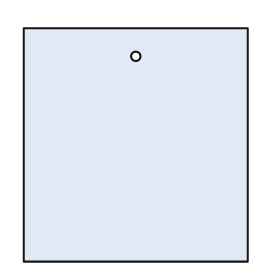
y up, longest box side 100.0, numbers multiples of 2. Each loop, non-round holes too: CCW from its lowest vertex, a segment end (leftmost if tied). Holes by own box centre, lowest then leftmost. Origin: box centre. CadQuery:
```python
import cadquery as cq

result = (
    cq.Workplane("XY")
    .moveTo(-48.0, -50.0)
    .lineTo(48.0, -50.0)
    .lineTo(48.0, 50.0)
    .lineTo(-48.0, 50.0)
    .close()
    .moveTo(0.0, 38.0)
    .circle(2.0)
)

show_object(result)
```